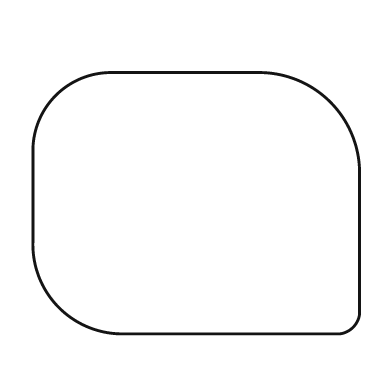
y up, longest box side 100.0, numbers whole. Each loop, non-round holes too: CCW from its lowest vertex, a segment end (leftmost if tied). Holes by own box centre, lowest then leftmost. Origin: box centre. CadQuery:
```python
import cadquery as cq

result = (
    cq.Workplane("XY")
    .moveTo(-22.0, -40.0)
    .lineTo(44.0, -40.0)
    .threePointArc((48.0, -38.0), (50.0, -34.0))
    .lineTo(50.0, 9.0)
    .threePointArc((41.0, 31.0), (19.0, 40.0))
    .lineTo(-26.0, 40.0)
    .threePointArc((-43.0, 33.0), (-50.0, 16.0))
    .lineTo(-50.0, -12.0)
    .threePointArc((-42.0, -32.0), (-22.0, -40.0))
    .close()
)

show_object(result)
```